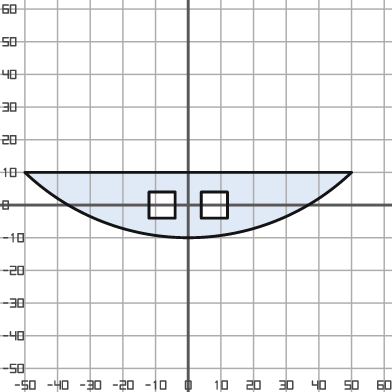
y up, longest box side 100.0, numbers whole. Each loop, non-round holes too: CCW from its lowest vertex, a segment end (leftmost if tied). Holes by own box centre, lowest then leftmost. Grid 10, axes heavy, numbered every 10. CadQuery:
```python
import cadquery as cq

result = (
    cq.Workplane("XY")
    .moveTo(-50.0, 10.0)
    .threePointArc((0.0, -10.0), (50.0, 10.0))
    .close()
    .moveTo(-12.0, -4.0)
    .lineTo(-4.0, -4.0)
    .lineTo(-4.0, 4.0)
    .lineTo(-12.0, 4.0)
    .close()
    .moveTo(4.0, -4.0)
    .lineTo(12.0, -4.0)
    .lineTo(12.0, 4.0)
    .lineTo(4.0, 4.0)
    .close()
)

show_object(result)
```